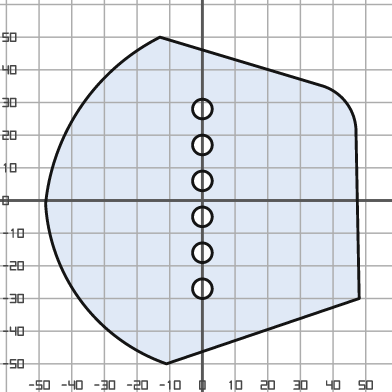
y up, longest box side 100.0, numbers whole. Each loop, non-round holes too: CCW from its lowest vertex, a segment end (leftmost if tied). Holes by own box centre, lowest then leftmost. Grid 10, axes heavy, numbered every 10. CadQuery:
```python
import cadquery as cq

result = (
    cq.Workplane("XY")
    .moveTo(-11.0, -50.0)
    .lineTo(48.0, -30.0)
    .lineTo(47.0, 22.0)
    .threePointArc((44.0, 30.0), (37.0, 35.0))
    .lineTo(-13.0, 50.0)
    .threePointArc((-37.0, 29.0), (-48.0, -1.0))
    .threePointArc((-37.0, -31.0), (-11.0, -50.0))
    .close()
    .moveTo(0.0, -27.0)
    .circle(3.0)
    .moveTo(0.0, -16.0)
    .circle(3.0)
    .moveTo(0.0, -5.0)
    .circle(3.0)
    .moveTo(0.0, 6.0)
    .circle(3.0)
    .moveTo(0.0, 17.0)
    .circle(3.0)
    .moveTo(0.0, 28.0)
    .circle(3.0)
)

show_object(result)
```